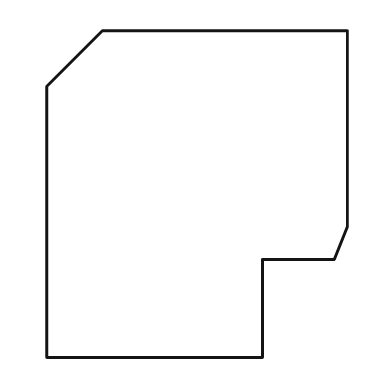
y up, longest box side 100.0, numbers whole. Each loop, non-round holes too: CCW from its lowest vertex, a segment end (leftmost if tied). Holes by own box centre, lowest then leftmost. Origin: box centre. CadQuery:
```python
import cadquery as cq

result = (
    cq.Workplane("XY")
    .moveTo(-46.0, -50.0)
    .lineTo(20.0, -50.0)
    .lineTo(20.0, -20.0)
    .lineTo(42.0, -20.0)
    .lineTo(46.0, -10.0)
    .lineTo(46.0, 50.0)
    .lineTo(-29.0, 50.0)
    .lineTo(-46.0, 33.0)
    .close()
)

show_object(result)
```